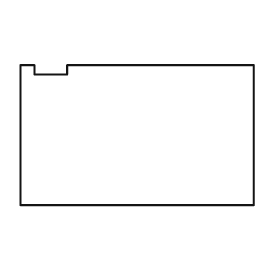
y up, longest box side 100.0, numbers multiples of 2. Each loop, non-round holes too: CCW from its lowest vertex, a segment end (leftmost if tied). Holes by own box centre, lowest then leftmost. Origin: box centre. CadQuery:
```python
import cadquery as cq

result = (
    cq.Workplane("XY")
    .moveTo(-50.0, -30.0)
    .lineTo(50.0, -30.0)
    .lineTo(50.0, 30.0)
    .lineTo(-30.0, 30.0)
    .lineTo(-30.0, 26.0)
    .lineTo(-44.0, 26.0)
    .lineTo(-44.0, 30.0)
    .lineTo(-50.0, 30.0)
    .close()
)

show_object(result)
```